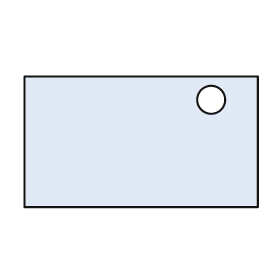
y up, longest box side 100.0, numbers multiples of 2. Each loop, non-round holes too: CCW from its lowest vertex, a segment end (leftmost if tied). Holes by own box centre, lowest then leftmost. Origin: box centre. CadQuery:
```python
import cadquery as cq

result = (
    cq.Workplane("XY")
    .moveTo(-50.0, -28.0)
    .lineTo(50.0, -28.0)
    .lineTo(50.0, 28.0)
    .lineTo(-50.0, 28.0)
    .close()
    .moveTo(30.0, 18.0)
    .circle(6.0)
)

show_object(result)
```